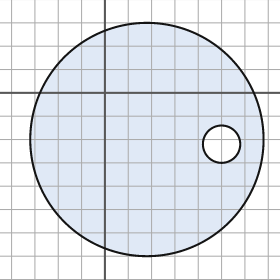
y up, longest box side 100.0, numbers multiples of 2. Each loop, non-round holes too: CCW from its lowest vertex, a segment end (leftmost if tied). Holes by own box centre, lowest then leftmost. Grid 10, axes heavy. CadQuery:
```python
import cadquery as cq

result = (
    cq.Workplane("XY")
    .moveTo(18.0, -20.0)
    .circle(50.0)
    .moveTo(50.0, -22.0)
    .circle(8.0)
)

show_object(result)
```